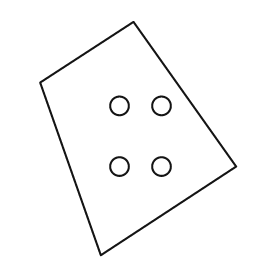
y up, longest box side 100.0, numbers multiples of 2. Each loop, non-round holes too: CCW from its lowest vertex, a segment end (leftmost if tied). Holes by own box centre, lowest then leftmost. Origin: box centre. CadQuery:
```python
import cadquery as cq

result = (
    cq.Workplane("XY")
    .moveTo(-16.0, -50.0)
    .lineTo(42.0, -12.0)
    .lineTo(-2.0, 50.0)
    .lineTo(-42.0, 24.0)
    .close()
    .moveTo(-8.0, -12.0)
    .circle(4.0)
    .moveTo(10.0, -12.0)
    .circle(4.0)
    .moveTo(-8.0, 14.0)
    .circle(4.0)
    .moveTo(10.0, 14.0)
    .circle(4.0)
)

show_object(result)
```